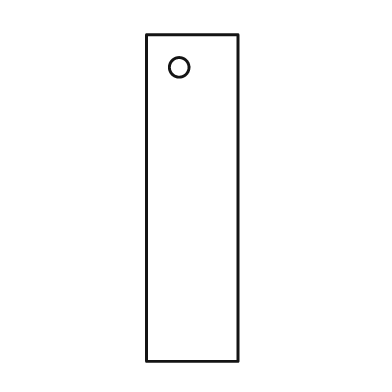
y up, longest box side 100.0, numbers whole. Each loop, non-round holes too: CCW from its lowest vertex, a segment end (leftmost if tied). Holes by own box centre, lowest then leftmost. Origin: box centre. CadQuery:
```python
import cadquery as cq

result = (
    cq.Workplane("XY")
    .moveTo(-14.0, -50.0)
    .lineTo(14.0, -50.0)
    .lineTo(14.0, 50.0)
    .lineTo(-14.0, 50.0)
    .close()
    .moveTo(-4.0, 40.0)
    .circle(3.0)
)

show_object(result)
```